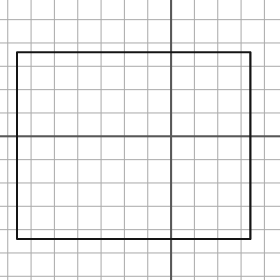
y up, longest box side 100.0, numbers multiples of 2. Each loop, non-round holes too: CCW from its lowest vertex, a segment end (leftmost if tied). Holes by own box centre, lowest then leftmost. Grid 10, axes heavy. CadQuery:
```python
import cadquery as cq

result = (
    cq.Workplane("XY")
    .moveTo(-66.0, -44.0)
    .lineTo(34.0, -44.0)
    .lineTo(34.0, 36.0)
    .lineTo(-66.0, 36.0)
    .close()
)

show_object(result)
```